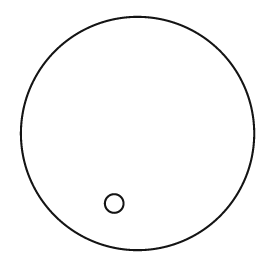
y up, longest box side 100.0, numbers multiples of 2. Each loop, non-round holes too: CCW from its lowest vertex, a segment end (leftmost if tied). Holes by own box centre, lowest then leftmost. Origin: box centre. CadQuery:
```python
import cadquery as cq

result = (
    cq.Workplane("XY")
    .moveTo(0.0, 0.0)
    .circle(50.0)
    .moveTo(-10.0, -30.0)
    .circle(4.0)
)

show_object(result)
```